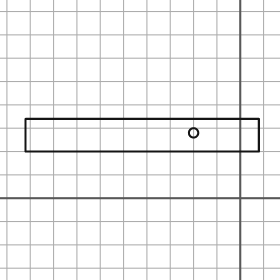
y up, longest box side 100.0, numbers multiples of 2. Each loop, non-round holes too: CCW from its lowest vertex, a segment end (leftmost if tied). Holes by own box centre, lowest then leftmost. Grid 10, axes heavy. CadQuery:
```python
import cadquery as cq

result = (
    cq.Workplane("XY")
    .moveTo(-92.0, 20.0)
    .lineTo(8.0, 20.0)
    .lineTo(8.0, 34.0)
    .lineTo(-92.0, 34.0)
    .close()
    .moveTo(-20.0, 28.0)
    .circle(2.0)
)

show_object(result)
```